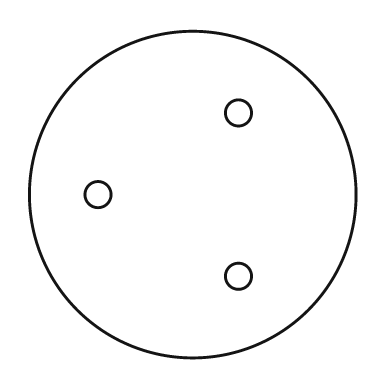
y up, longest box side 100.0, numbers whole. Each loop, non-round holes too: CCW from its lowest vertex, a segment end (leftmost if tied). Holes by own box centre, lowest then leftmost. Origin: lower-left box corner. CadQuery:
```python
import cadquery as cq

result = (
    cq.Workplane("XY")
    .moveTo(50.0, 50.0)
    .circle(50.0)
    .moveTo(64.0, 25.0)
    .circle(4.0)
    .moveTo(21.0, 50.0)
    .circle(4.0)
    .moveTo(64.0, 75.0)
    .circle(4.0)
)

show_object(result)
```